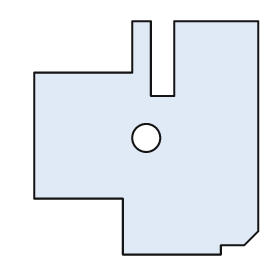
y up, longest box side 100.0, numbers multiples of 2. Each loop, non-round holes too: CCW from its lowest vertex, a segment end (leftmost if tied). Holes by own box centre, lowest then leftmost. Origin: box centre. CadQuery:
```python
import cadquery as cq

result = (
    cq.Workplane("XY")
    .moveTo(-10.0, -50.0)
    .lineTo(32.0, -50.0)
    .lineTo(32.0, -46.0)
    .lineTo(42.0, -46.0)
    .lineTo(48.0, -40.0)
    .lineTo(48.0, 50.0)
    .lineTo(12.0, 50.0)
    .lineTo(12.0, 18.0)
    .lineTo(2.0, 18.0)
    .lineTo(2.0, 50.0)
    .lineTo(-6.0, 50.0)
    .lineTo(-6.0, 28.0)
    .lineTo(-48.0, 28.0)
    .lineTo(-48.0, -26.0)
    .lineTo(-10.0, -26.0)
    .close()
    .moveTo(0.0, 0.0)
    .circle(6.0)
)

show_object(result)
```